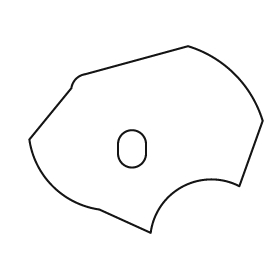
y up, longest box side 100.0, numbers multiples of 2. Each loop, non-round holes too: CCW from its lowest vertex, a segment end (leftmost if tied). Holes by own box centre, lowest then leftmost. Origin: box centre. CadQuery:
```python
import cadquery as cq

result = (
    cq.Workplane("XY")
    .moveTo(2.0, -40.0)
    .threePointArc((16.0, -20.0), (40.0, -20.0))
    .lineTo(50.0, 8.0)
    .threePointArc((38.0, 28.0), (18.0, 40.0))
    .lineTo(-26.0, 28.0)
    .threePointArc((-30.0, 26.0), (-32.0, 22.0))
    .lineTo(-50.0, 0.0)
    .threePointArc((-40.0, -20.0), (-20.0, -30.0))
    .close()
    .moveTo(-12.0, -6.0)
    .threePointArc((-6.0, -12.0), (0.0, -6.0))
    .lineTo(0.0, -2.0)
    .threePointArc((-6.0, 4.0), (-12.0, -2.0))
    .close()
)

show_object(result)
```